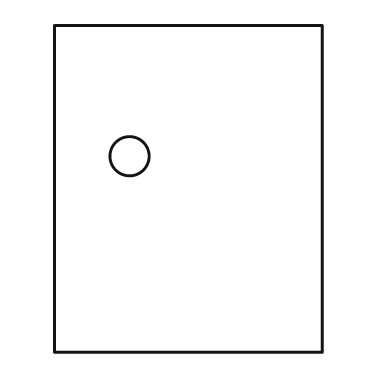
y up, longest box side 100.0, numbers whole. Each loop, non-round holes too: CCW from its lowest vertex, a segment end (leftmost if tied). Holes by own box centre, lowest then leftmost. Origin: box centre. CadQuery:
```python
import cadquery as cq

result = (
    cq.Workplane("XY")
    .moveTo(-41.0, -50.0)
    .lineTo(41.0, -50.0)
    .lineTo(41.0, 50.0)
    .lineTo(-41.0, 50.0)
    .close()
    .moveTo(-18.0, 10.0)
    .circle(6.0)
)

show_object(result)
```